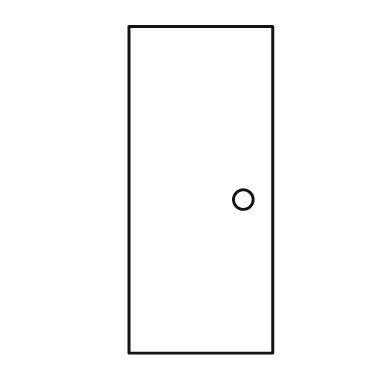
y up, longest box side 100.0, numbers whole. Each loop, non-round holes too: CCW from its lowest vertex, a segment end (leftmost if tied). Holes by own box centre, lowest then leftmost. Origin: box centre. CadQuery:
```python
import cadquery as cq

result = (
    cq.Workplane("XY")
    .moveTo(-22.0, -50.0)
    .lineTo(22.0, -50.0)
    .lineTo(22.0, 50.0)
    .lineTo(-22.0, 50.0)
    .close()
    .moveTo(13.0, -3.0)
    .circle(3.0)
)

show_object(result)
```